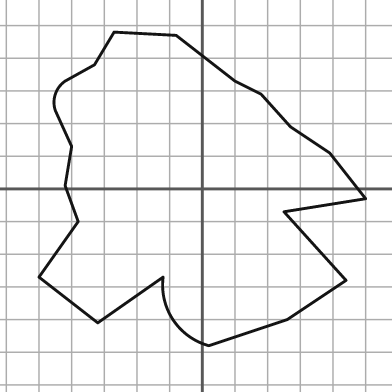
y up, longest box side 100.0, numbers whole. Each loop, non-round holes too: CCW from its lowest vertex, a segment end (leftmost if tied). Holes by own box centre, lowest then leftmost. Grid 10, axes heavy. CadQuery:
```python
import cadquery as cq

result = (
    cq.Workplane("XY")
    .moveTo(2.0, -48.0)
    .lineTo(26.0, -40.0)
    .lineTo(44.0, -28.0)
    .lineTo(25.0, -7.0)
    .lineTo(50.0, -3.0)
    .lineTo(39.0, 11.0)
    .lineTo(27.0, 19.0)
    .lineTo(18.0, 29.0)
    .lineTo(10.0, 33.0)
    .lineTo(-8.0, 47.0)
    .lineTo(-27.0, 48.0)
    .lineTo(-33.0, 38.0)
    .lineTo(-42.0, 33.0)
    .threePointArc((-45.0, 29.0), (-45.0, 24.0))
    .lineTo(-40.0, 13.0)
    .lineTo(-42.0, 1.0)
    .lineTo(-38.0, -10.0)
    .lineTo(-50.0, -27.0)
    .lineTo(-32.0, -41.0)
    .lineTo(-12.0, -27.0)
    .threePointArc((-9.0, -40.0), (2.0, -48.0))
    .close()
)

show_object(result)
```